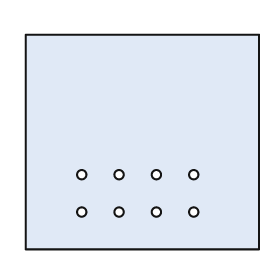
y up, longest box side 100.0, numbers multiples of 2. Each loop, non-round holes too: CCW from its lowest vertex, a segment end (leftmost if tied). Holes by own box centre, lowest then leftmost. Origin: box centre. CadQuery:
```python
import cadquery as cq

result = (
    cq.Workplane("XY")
    .moveTo(-50.0, -46.0)
    .lineTo(50.0, -46.0)
    .lineTo(50.0, 46.0)
    .lineTo(-50.0, 46.0)
    .close()
    .moveTo(-26.0, -30.0)
    .circle(2.0)
    .moveTo(-10.0, -30.0)
    .circle(2.0)
    .moveTo(6.0, -30.0)
    .circle(2.0)
    .moveTo(22.0, -30.0)
    .circle(2.0)
    .moveTo(-26.0, -14.0)
    .circle(2.0)
    .moveTo(-10.0, -14.0)
    .circle(2.0)
    .moveTo(6.0, -14.0)
    .circle(2.0)
    .moveTo(22.0, -14.0)
    .circle(2.0)
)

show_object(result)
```